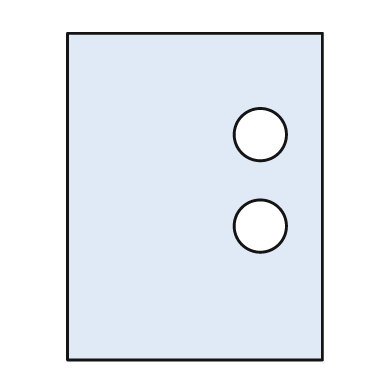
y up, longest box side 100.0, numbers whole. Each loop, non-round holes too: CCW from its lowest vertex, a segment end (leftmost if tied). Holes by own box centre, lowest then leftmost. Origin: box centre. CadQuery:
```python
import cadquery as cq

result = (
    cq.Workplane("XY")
    .moveTo(-39.0, -50.0)
    .lineTo(39.0, -50.0)
    .lineTo(39.0, 50.0)
    .lineTo(-39.0, 50.0)
    .close()
    .moveTo(20.0, -9.0)
    .circle(8.0)
    .moveTo(20.0, 19.0)
    .circle(8.0)
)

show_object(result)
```